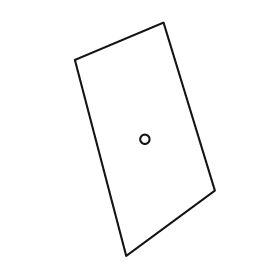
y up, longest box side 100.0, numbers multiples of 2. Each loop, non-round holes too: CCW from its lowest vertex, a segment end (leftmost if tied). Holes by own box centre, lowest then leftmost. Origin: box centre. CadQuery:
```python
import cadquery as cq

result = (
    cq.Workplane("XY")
    .moveTo(-8.0, -50.0)
    .lineTo(30.0, -22.0)
    .lineTo(8.0, 50.0)
    .lineTo(-30.0, 34.0)
    .close()
    .moveTo(0.0, 0.0)
    .circle(2.0)
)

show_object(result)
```